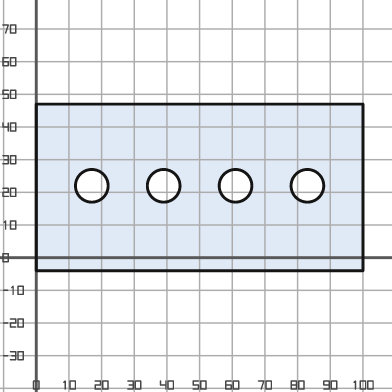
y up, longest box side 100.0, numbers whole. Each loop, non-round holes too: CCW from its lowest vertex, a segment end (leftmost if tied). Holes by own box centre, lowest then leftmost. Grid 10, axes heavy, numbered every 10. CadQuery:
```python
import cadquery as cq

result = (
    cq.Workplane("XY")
    .moveTo(0.0, -4.0)
    .lineTo(100.0, -4.0)
    .lineTo(100.0, 47.0)
    .lineTo(0.0, 47.0)
    .close()
    .moveTo(17.0, 22.0)
    .circle(5.0)
    .moveTo(39.0, 22.0)
    .circle(5.0)
    .moveTo(61.0, 22.0)
    .circle(5.0)
    .moveTo(83.0, 22.0)
    .circle(5.0)
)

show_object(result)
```